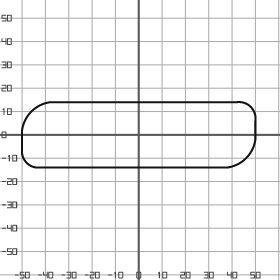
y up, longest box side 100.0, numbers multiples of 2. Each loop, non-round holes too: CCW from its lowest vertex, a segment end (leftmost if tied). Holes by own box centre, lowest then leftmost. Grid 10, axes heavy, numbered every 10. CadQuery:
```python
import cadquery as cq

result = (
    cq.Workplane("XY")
    .moveTo(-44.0, -14.0)
    .lineTo(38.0, -14.0)
    .threePointArc((46.0, -10.0), (50.0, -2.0))
    .lineTo(50.0, 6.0)
    .threePointArc((48.0, 12.0), (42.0, 14.0))
    .lineTo(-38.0, 14.0)
    .threePointArc((-46.0, 10.0), (-50.0, 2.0))
    .lineTo(-50.0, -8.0)
    .threePointArc((-48.0, -12.0), (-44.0, -14.0))
    .close()
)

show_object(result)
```